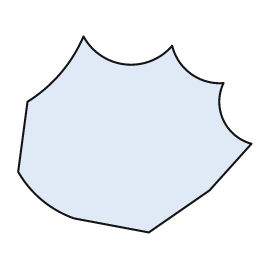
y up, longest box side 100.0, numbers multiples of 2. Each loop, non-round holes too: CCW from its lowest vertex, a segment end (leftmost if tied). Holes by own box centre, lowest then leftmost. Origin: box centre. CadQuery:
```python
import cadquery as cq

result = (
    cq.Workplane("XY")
    .moveTo(6.0, -42.0)
    .lineTo(32.0, -24.0)
    .lineTo(50.0, -4.0)
    .threePointArc((38.0, 6.0), (38.0, 22.0))
    .threePointArc((24.0, 26.0), (16.0, 38.0))
    .threePointArc((-4.0, 30.0), (-22.0, 42.0))
    .threePointArc((-32.0, 26.0), (-46.0, 14.0))
    .lineTo(-50.0, -16.0)
    .threePointArc((-40.0, -28.0), (-26.0, -36.0))
    .close()
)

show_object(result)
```